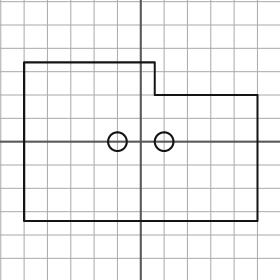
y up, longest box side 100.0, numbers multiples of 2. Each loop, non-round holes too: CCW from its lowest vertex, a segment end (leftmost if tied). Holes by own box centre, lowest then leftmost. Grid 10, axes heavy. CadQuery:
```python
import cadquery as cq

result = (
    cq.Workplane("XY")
    .moveTo(-50.0, -34.0)
    .lineTo(50.0, -34.0)
    .lineTo(50.0, 20.0)
    .lineTo(6.0, 20.0)
    .lineTo(6.0, 34.0)
    .lineTo(-50.0, 34.0)
    .close()
    .moveTo(-10.0, 0.0)
    .circle(4.0)
    .moveTo(10.0, 0.0)
    .circle(4.0)
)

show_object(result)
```